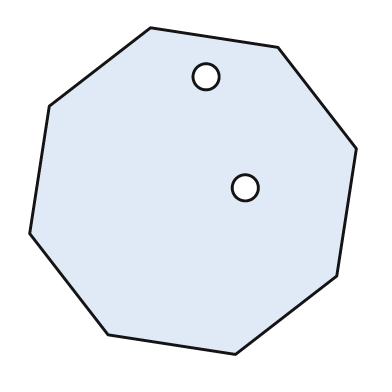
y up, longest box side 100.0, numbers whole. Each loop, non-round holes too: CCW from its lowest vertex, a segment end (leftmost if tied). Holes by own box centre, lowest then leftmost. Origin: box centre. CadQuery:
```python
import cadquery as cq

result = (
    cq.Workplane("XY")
    .moveTo(13.0, -50.0)
    .lineTo(44.0, -26.0)
    .lineTo(50.0, 13.0)
    .lineTo(26.0, 44.0)
    .lineTo(-13.0, 50.0)
    .lineTo(-44.0, 26.0)
    .lineTo(-50.0, -13.0)
    .lineTo(-26.0, -44.0)
    .close()
    .moveTo(16.0, 1.0)
    .circle(4.0)
    .moveTo(4.0, 35.0)
    .circle(4.0)
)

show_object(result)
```